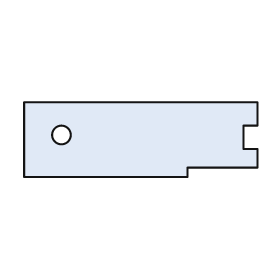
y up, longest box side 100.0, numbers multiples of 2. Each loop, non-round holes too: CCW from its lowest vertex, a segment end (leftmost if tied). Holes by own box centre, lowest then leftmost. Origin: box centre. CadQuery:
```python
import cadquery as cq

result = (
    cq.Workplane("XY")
    .moveTo(-50.0, -16.0)
    .lineTo(20.0, -16.0)
    .lineTo(20.0, -12.0)
    .lineTo(50.0, -12.0)
    .lineTo(50.0, -4.0)
    .lineTo(44.0, -4.0)
    .lineTo(44.0, 6.0)
    .lineTo(50.0, 6.0)
    .lineTo(50.0, 16.0)
    .lineTo(-50.0, 16.0)
    .close()
    .moveTo(-34.0, 2.0)
    .circle(4.0)
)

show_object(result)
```